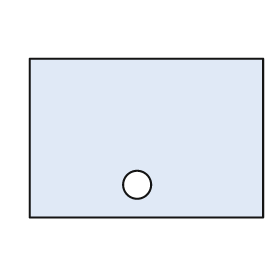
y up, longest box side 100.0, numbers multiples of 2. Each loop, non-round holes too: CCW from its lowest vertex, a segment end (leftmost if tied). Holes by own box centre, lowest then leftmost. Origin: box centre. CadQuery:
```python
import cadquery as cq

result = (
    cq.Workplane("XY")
    .moveTo(-50.0, -34.0)
    .lineTo(50.0, -34.0)
    .lineTo(50.0, 34.0)
    .lineTo(-50.0, 34.0)
    .close()
    .moveTo(-4.0, -20.0)
    .circle(6.0)
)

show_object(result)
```